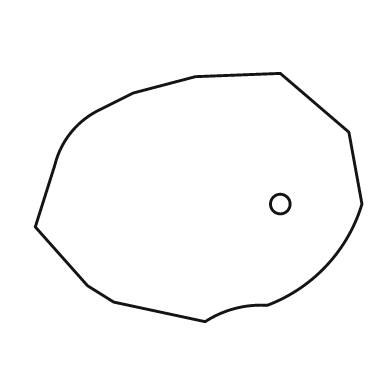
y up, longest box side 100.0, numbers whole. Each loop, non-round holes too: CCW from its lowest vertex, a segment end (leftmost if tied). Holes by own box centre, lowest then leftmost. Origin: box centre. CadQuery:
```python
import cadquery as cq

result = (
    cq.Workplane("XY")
    .moveTo(2.0, -38.0)
    .threePointArc((11.0, -34.0), (21.0, -33.0))
    .threePointArc((39.0, -21.0), (50.0, -2.0))
    .lineTo(46.0, 20.0)
    .lineTo(25.0, 38.0)
    .lineTo(-1.0, 37.0)
    .lineTo(-20.0, 32.0)
    .lineTo(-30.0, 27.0)
    .threePointArc((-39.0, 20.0), (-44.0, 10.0))
    .lineTo(-50.0, -9.0)
    .lineTo(-34.0, -27.0)
    .lineTo(-26.0, -32.0)
    .close()
    .moveTo(25.0, -2.0)
    .circle(3.0)
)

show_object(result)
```